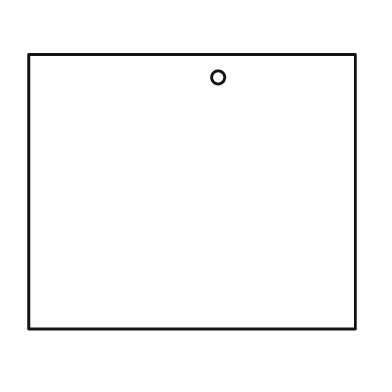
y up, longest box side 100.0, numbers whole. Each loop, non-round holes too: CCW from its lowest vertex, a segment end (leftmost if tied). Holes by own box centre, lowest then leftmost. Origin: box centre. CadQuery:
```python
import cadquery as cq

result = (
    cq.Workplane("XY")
    .moveTo(-50.0, -42.0)
    .lineTo(50.0, -42.0)
    .lineTo(50.0, 42.0)
    .lineTo(-50.0, 42.0)
    .close()
    .moveTo(8.0, 35.0)
    .circle(2.0)
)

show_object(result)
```